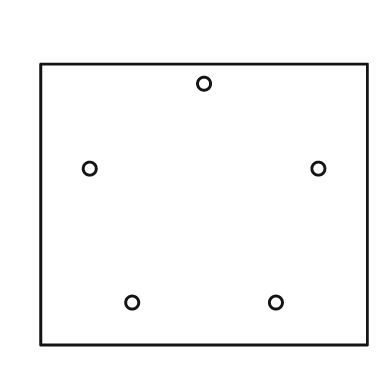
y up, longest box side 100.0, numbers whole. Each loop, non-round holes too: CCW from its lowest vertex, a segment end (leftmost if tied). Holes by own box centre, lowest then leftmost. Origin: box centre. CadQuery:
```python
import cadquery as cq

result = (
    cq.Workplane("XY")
    .moveTo(-50.0, -43.0)
    .lineTo(50.0, -43.0)
    .lineTo(50.0, 43.0)
    .lineTo(-50.0, 43.0)
    .close()
    .moveTo(-22.0, -30.0)
    .circle(2.0)
    .moveTo(22.0, -30.0)
    .circle(2.0)
    .moveTo(-35.0, 11.0)
    .circle(2.0)
    .moveTo(35.0, 11.0)
    .circle(2.0)
    .moveTo(0.0, 37.0)
    .circle(2.0)
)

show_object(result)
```